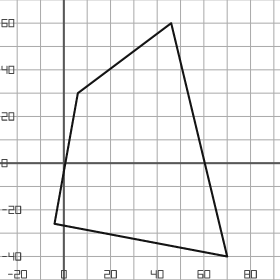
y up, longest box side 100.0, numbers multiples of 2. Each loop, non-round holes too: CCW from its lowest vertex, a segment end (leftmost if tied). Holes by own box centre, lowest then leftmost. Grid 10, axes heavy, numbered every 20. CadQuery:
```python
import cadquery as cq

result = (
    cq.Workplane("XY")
    .moveTo(70.0, -40.0)
    .lineTo(46.0, 60.0)
    .lineTo(6.0, 30.0)
    .lineTo(-4.0, -26.0)
    .close()
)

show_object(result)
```